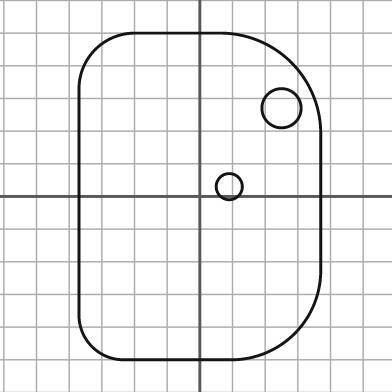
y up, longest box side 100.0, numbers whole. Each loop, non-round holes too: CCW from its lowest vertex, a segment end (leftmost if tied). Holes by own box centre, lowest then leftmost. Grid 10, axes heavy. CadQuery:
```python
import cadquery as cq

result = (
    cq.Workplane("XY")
    .moveTo(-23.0, -50.0)
    .lineTo(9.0, -50.0)
    .threePointArc((29.0, -42.0), (37.0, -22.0))
    .lineTo(37.0, 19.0)
    .threePointArc((28.0, 41.0), (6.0, 50.0))
    .lineTo(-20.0, 50.0)
    .threePointArc((-32.0, 45.0), (-37.0, 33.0))
    .lineTo(-37.0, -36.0)
    .threePointArc((-33.0, -46.0), (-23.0, -50.0))
    .close()
    .moveTo(9.0, 3.0)
    .circle(4.0)
    .moveTo(25.0, 27.0)
    .circle(6.0)
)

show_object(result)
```